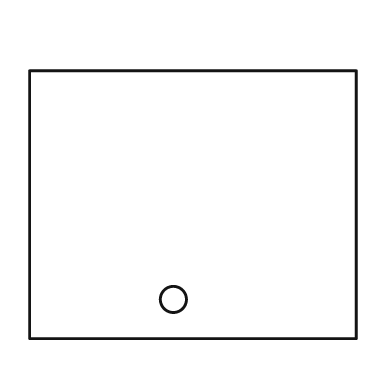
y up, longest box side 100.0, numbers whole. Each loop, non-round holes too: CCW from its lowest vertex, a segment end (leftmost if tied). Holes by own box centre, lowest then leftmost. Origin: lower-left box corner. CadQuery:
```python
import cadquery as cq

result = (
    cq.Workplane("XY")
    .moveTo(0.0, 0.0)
    .lineTo(100.0, 0.0)
    .lineTo(100.0, 82.0)
    .lineTo(0.0, 82.0)
    .close()
    .moveTo(44.0, 12.0)
    .circle(4.0)
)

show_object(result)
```